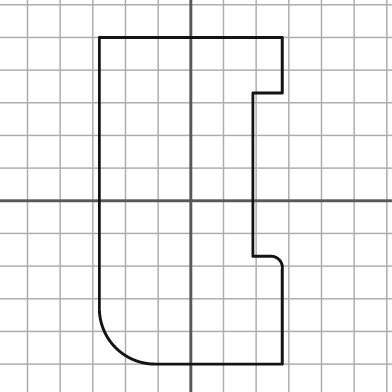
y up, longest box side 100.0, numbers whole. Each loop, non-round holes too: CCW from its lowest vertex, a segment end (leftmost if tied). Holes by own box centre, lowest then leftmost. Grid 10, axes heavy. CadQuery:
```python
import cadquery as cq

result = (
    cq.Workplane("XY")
    .moveTo(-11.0, -50.0)
    .lineTo(28.0, -50.0)
    .lineTo(28.0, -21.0)
    .threePointArc((27.0, -18.0), (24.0, -17.0))
    .lineTo(19.0, -17.0)
    .lineTo(19.0, 33.0)
    .lineTo(28.0, 33.0)
    .lineTo(28.0, 50.0)
    .lineTo(-28.0, 50.0)
    .lineTo(-28.0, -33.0)
    .threePointArc((-23.0, -45.0), (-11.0, -50.0))
    .close()
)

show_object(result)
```